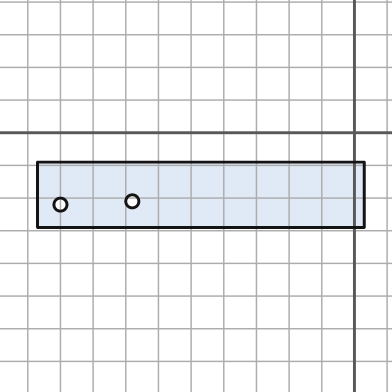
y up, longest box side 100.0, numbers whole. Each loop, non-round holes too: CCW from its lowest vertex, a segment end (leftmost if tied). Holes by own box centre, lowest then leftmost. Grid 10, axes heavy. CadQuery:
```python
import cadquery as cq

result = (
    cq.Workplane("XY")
    .moveTo(-97.0, -29.0)
    .lineTo(3.0, -29.0)
    .lineTo(3.0, -9.0)
    .lineTo(-97.0, -9.0)
    .close()
    .moveTo(-90.0, -22.0)
    .circle(2.0)
    .moveTo(-68.0, -21.0)
    .circle(2.0)
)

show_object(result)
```